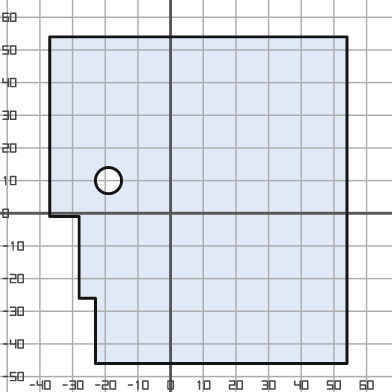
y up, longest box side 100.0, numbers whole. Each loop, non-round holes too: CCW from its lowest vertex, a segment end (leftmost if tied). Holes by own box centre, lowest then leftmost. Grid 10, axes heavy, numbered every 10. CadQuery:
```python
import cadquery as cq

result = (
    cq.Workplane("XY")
    .moveTo(-23.0, -46.0)
    .lineTo(54.0, -46.0)
    .lineTo(54.0, 54.0)
    .lineTo(-37.0, 54.0)
    .lineTo(-37.0, -1.0)
    .lineTo(-28.0, -1.0)
    .lineTo(-28.0, -26.0)
    .lineTo(-23.0, -26.0)
    .close()
    .moveTo(-19.0, 10.0)
    .circle(4.0)
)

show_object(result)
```